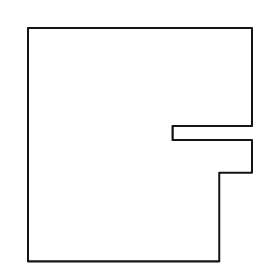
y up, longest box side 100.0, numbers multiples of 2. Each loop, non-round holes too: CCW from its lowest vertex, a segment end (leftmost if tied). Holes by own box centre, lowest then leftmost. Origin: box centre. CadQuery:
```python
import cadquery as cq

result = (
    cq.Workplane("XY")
    .moveTo(-48.0, -50.0)
    .lineTo(34.0, -50.0)
    .lineTo(34.0, -12.0)
    .lineTo(48.0, -12.0)
    .lineTo(48.0, 2.0)
    .lineTo(14.0, 2.0)
    .lineTo(14.0, 8.0)
    .lineTo(48.0, 8.0)
    .lineTo(48.0, 50.0)
    .lineTo(-48.0, 50.0)
    .close()
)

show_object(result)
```